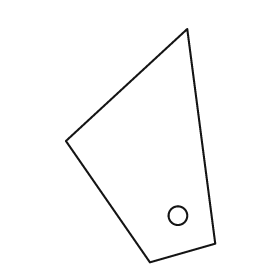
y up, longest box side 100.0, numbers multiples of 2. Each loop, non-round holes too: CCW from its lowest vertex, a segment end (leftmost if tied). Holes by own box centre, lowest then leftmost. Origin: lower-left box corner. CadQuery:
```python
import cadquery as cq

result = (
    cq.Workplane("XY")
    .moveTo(36.0, 0.0)
    .lineTo(64.0, 8.0)
    .lineTo(52.0, 100.0)
    .lineTo(0.0, 52.0)
    .close()
    .moveTo(48.0, 20.0)
    .circle(4.0)
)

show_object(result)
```